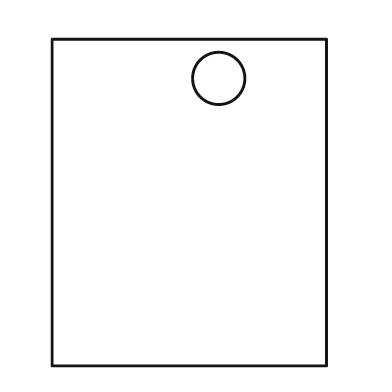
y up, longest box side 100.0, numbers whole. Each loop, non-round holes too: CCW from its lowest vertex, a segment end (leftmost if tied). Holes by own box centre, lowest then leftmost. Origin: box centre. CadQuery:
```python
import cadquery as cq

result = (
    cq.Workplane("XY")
    .moveTo(-42.0, -50.0)
    .lineTo(42.0, -50.0)
    .lineTo(42.0, 50.0)
    .lineTo(-42.0, 50.0)
    .close()
    .moveTo(9.0, 38.0)
    .circle(8.0)
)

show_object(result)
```